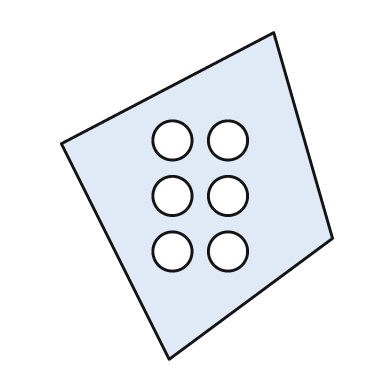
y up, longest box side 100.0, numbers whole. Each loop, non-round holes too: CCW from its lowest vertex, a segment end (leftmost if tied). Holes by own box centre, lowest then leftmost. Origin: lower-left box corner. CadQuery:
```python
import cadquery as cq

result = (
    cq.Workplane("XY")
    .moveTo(33.0, 0.0)
    .lineTo(83.0, 37.0)
    .lineTo(65.0, 100.0)
    .lineTo(0.0, 66.0)
    .close()
    .moveTo(34.0, 33.0)
    .circle(6.0)
    .moveTo(51.0, 33.0)
    .circle(6.0)
    .moveTo(34.0, 50.0)
    .circle(6.0)
    .moveTo(51.0, 50.0)
    .circle(6.0)
    .moveTo(34.0, 67.0)
    .circle(6.0)
    .moveTo(51.0, 67.0)
    .circle(6.0)
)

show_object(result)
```